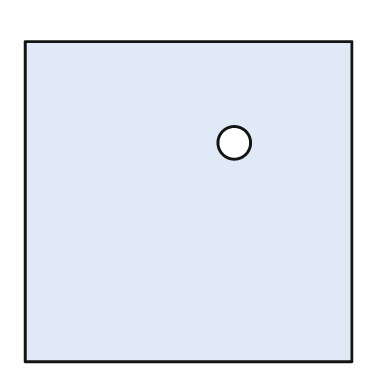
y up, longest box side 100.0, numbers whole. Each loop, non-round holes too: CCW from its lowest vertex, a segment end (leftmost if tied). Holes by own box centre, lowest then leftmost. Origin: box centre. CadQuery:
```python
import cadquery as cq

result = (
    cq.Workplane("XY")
    .moveTo(-50.0, -49.0)
    .lineTo(50.0, -49.0)
    .lineTo(50.0, 49.0)
    .lineTo(-50.0, 49.0)
    .close()
    .moveTo(14.0, 18.0)
    .circle(5.0)
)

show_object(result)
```